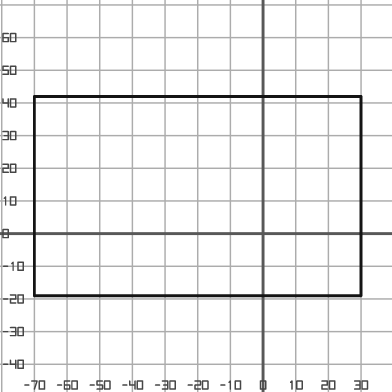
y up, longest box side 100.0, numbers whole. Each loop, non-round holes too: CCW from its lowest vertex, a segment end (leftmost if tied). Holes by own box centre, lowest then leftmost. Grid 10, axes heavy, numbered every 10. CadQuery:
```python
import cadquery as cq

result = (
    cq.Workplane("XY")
    .moveTo(-70.0, -19.0)
    .lineTo(30.0, -19.0)
    .lineTo(30.0, 42.0)
    .lineTo(-70.0, 42.0)
    .close()
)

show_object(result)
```